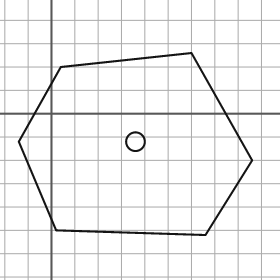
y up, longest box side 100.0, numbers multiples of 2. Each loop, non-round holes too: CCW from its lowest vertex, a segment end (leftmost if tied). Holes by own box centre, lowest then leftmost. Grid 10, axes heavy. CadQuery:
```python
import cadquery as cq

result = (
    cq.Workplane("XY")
    .moveTo(66.0, -52.0)
    .lineTo(86.0, -20.0)
    .lineTo(60.0, 26.0)
    .lineTo(4.0, 20.0)
    .lineTo(-14.0, -12.0)
    .lineTo(2.0, -50.0)
    .close()
    .moveTo(36.0, -12.0)
    .circle(4.0)
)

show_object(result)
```